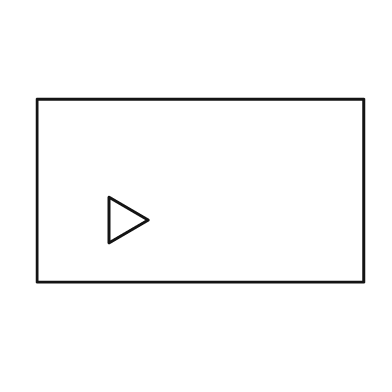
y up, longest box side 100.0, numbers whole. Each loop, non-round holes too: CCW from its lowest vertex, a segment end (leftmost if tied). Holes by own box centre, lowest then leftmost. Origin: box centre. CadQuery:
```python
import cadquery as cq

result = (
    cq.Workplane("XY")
    .moveTo(-50.0, -28.0)
    .lineTo(50.0, -28.0)
    .lineTo(50.0, 28.0)
    .lineTo(-50.0, 28.0)
    .close()
    .moveTo(-28.0, -16.0)
    .lineTo(-16.0, -9.0)
    .lineTo(-28.0, -2.0)
    .close()
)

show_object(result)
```